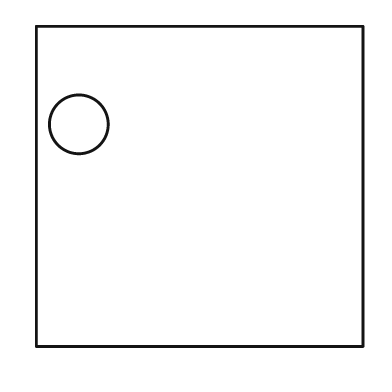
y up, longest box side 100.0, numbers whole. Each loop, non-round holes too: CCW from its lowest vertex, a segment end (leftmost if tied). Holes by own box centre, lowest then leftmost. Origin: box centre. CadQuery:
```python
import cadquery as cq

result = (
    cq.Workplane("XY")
    .moveTo(-50.0, -49.0)
    .lineTo(50.0, -49.0)
    .lineTo(50.0, 49.0)
    .lineTo(-50.0, 49.0)
    .close()
    .moveTo(-37.0, 19.0)
    .circle(9.0)
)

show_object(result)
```